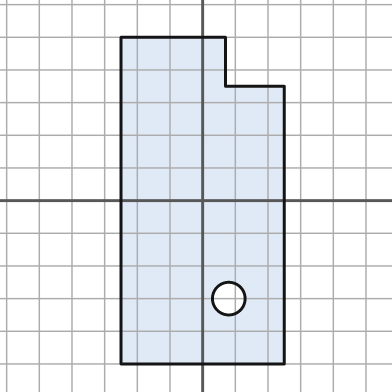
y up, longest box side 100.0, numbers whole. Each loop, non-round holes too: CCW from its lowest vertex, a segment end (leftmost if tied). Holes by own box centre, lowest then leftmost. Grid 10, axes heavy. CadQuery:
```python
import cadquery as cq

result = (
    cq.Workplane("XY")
    .moveTo(-25.0, -50.0)
    .lineTo(25.0, -50.0)
    .lineTo(25.0, 35.0)
    .lineTo(7.0, 35.0)
    .lineTo(7.0, 50.0)
    .lineTo(-25.0, 50.0)
    .close()
    .moveTo(8.0, -30.0)
    .circle(5.0)
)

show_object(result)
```